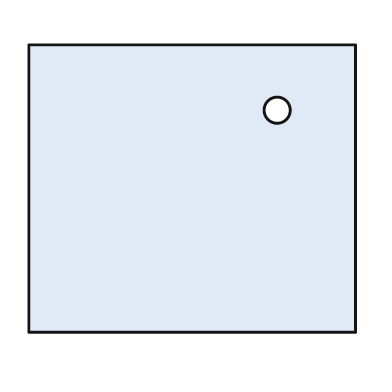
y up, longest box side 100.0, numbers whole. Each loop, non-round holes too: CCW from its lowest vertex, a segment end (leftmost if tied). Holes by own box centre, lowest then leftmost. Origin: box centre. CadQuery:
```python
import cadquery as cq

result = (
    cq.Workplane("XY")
    .moveTo(-50.0, -44.0)
    .lineTo(50.0, -44.0)
    .lineTo(50.0, 44.0)
    .lineTo(-50.0, 44.0)
    .close()
    .moveTo(26.0, 24.0)
    .circle(4.0)
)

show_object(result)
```